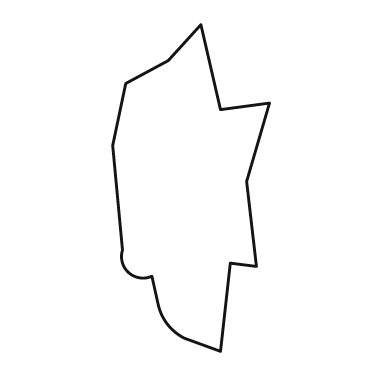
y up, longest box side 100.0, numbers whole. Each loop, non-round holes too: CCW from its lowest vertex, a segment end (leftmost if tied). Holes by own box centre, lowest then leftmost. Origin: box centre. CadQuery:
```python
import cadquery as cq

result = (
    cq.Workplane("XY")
    .moveTo(9.0, -50.0)
    .lineTo(12.0, -23.0)
    .lineTo(20.0, -24.0)
    .lineTo(17.0, 2.0)
    .lineTo(24.0, 26.0)
    .lineTo(9.0, 24.0)
    .lineTo(3.0, 50.0)
    .lineTo(-7.0, 39.0)
    .lineTo(-20.0, 32.0)
    .lineTo(-24.0, 13.0)
    .lineTo(-21.0, -19.0)
    .threePointArc((-19.0, -26.0), (-12.0, -27.0))
    .lineTo(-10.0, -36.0)
    .threePointArc((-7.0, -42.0), (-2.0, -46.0))
    .close()
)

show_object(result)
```